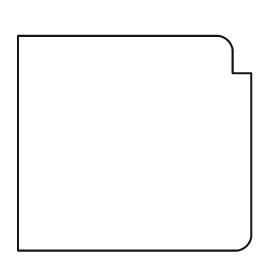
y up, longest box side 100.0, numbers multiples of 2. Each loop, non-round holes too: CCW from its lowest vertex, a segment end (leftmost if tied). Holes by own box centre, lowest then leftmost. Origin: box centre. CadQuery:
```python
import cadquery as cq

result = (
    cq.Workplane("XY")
    .moveTo(-50.0, -46.0)
    .lineTo(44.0, -46.0)
    .threePointArc((48.0, -44.0), (50.0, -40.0))
    .lineTo(50.0, 30.0)
    .lineTo(42.0, 30.0)
    .lineTo(42.0, 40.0)
    .threePointArc((40.0, 44.0), (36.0, 46.0))
    .lineTo(-50.0, 46.0)
    .close()
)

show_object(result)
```